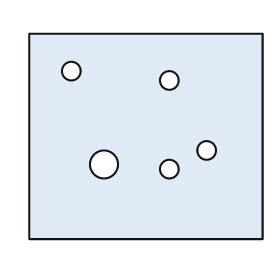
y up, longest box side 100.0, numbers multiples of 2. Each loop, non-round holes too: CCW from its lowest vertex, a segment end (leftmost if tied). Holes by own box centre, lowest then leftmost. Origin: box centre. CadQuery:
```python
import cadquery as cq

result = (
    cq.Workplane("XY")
    .moveTo(-50.0, -44.0)
    .lineTo(50.0, -44.0)
    .lineTo(50.0, 44.0)
    .lineTo(-50.0, 44.0)
    .close()
    .moveTo(10.0, -14.0)
    .circle(4.0)
    .moveTo(-18.0, -12.0)
    .circle(6.0)
    .moveTo(26.0, -6.0)
    .circle(4.0)
    .moveTo(10.0, 24.0)
    .circle(4.0)
    .moveTo(-32.0, 28.0)
    .circle(4.0)
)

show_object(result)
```